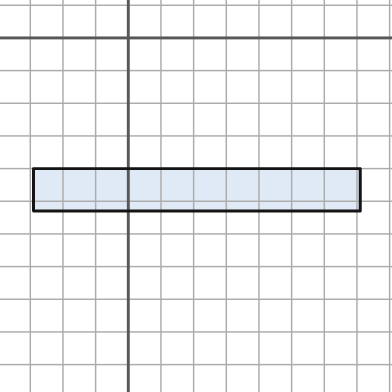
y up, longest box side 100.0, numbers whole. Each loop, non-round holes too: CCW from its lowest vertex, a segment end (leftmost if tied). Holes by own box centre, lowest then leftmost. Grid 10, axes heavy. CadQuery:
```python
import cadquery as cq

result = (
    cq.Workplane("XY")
    .moveTo(-29.0, -53.0)
    .lineTo(71.0, -53.0)
    .lineTo(71.0, -40.0)
    .lineTo(-29.0, -40.0)
    .close()
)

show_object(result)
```